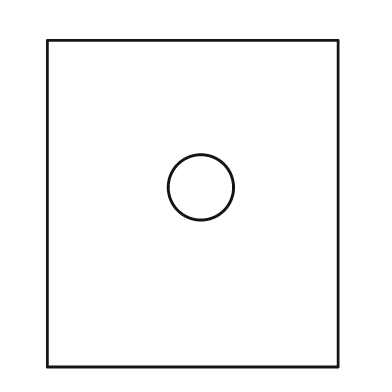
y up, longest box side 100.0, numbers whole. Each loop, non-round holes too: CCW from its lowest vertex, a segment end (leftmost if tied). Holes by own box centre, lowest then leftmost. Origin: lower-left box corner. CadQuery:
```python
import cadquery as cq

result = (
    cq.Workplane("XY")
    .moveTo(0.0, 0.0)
    .lineTo(89.0, 0.0)
    .lineTo(89.0, 100.0)
    .lineTo(0.0, 100.0)
    .close()
    .moveTo(47.0, 55.0)
    .circle(10.0)
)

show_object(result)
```